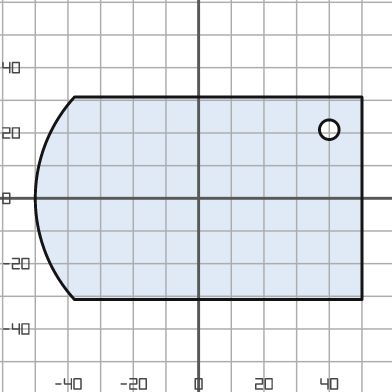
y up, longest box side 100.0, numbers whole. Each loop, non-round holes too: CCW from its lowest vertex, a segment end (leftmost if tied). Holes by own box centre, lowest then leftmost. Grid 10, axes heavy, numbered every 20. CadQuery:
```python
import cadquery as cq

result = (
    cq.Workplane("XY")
    .moveTo(-38.0, -31.0)
    .lineTo(50.0, -31.0)
    .lineTo(50.0, 31.0)
    .lineTo(-38.0, 31.0)
    .threePointArc((-50.0, 0.0), (-38.0, -31.0))
    .close()
    .moveTo(40.0, 21.0)
    .circle(3.0)
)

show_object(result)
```